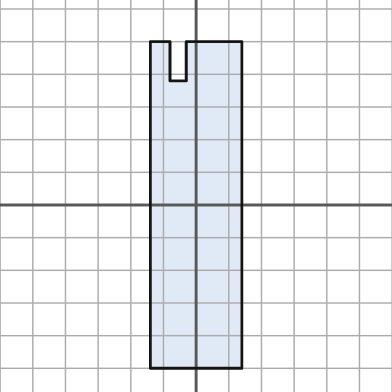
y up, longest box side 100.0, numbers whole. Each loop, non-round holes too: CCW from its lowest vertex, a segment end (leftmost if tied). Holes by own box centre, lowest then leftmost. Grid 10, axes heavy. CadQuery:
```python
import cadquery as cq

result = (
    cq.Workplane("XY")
    .moveTo(-14.0, -50.0)
    .lineTo(14.0, -50.0)
    .lineTo(14.0, 50.0)
    .lineTo(-3.0, 50.0)
    .lineTo(-3.0, 38.0)
    .lineTo(-8.0, 38.0)
    .lineTo(-8.0, 50.0)
    .lineTo(-14.0, 50.0)
    .close()
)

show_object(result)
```